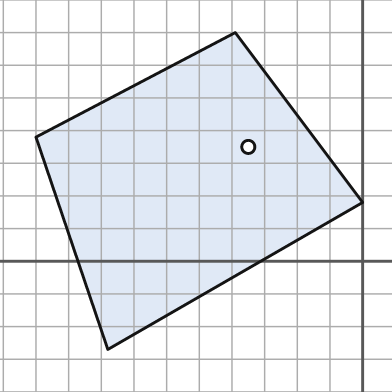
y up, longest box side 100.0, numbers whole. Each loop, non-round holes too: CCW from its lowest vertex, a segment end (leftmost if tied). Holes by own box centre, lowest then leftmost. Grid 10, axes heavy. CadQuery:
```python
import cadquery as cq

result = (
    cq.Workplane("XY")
    .moveTo(-78.0, -27.0)
    .lineTo(0.0, 18.0)
    .lineTo(-39.0, 70.0)
    .lineTo(-100.0, 38.0)
    .close()
    .moveTo(-35.0, 35.0)
    .circle(2.0)
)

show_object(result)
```